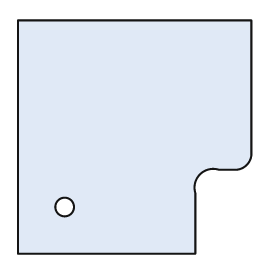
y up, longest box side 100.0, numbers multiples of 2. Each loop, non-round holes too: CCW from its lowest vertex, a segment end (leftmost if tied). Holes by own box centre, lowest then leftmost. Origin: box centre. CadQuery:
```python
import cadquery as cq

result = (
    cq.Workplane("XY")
    .moveTo(-50.0, -50.0)
    .lineTo(26.0, -50.0)
    .lineTo(26.0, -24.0)
    .threePointArc((28.0, -16.0), (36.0, -14.0))
    .lineTo(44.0, -14.0)
    .threePointArc((48.0, -12.0), (50.0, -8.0))
    .lineTo(50.0, 50.0)
    .lineTo(-50.0, 50.0)
    .close()
    .moveTo(-30.0, -30.0)
    .circle(4.0)
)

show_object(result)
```